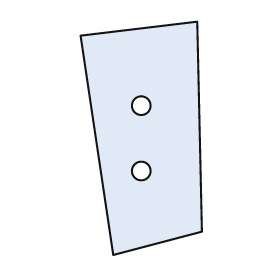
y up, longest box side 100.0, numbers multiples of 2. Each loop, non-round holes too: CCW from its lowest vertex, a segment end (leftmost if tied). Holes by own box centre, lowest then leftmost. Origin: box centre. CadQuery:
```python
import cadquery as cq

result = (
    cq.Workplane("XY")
    .moveTo(-12.0, -50.0)
    .lineTo(26.0, -40.0)
    .lineTo(24.0, 50.0)
    .lineTo(-26.0, 44.0)
    .close()
    .moveTo(0.0, -14.0)
    .circle(4.0)
    .moveTo(0.0, 14.0)
    .circle(4.0)
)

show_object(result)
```